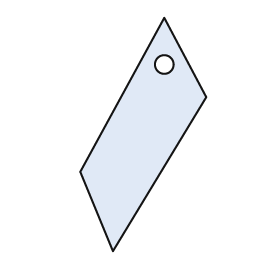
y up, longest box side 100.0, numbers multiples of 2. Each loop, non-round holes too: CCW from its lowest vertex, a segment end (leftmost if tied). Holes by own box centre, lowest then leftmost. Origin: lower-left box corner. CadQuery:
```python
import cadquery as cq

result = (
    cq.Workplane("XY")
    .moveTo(14.0, 0.0)
    .lineTo(54.0, 66.0)
    .lineTo(36.0, 100.0)
    .lineTo(0.0, 34.0)
    .close()
    .moveTo(36.0, 80.0)
    .circle(4.0)
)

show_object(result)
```